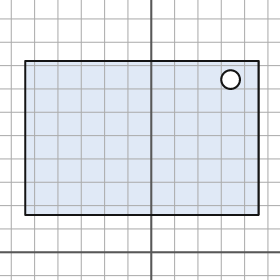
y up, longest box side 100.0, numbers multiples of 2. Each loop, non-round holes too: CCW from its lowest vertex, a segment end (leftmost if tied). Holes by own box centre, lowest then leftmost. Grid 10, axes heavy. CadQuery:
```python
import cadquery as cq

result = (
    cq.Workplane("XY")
    .moveTo(-54.0, 16.0)
    .lineTo(46.0, 16.0)
    .lineTo(46.0, 82.0)
    .lineTo(-54.0, 82.0)
    .close()
    .moveTo(34.0, 74.0)
    .circle(4.0)
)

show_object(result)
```